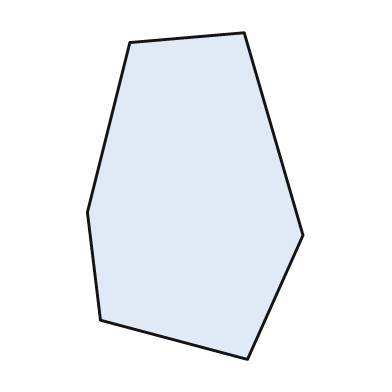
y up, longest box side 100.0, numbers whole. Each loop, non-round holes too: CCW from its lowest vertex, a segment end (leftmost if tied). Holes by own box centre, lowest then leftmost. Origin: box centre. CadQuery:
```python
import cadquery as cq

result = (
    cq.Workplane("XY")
    .moveTo(16.0, -50.0)
    .lineTo(33.0, -12.0)
    .lineTo(15.0, 50.0)
    .lineTo(-20.0, 47.0)
    .lineTo(-33.0, -5.0)
    .lineTo(-29.0, -38.0)
    .close()
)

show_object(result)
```